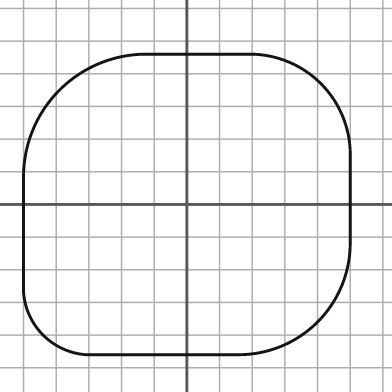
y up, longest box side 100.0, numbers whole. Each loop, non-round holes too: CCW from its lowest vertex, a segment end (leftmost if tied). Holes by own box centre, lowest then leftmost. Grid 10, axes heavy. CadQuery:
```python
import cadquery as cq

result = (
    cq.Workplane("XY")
    .moveTo(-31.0, -46.0)
    .lineTo(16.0, -46.0)
    .threePointArc((40.0, -36.0), (50.0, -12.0))
    .lineTo(50.0, 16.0)
    .threePointArc((41.0, 37.0), (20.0, 46.0))
    .lineTo(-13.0, 46.0)
    .threePointArc((-39.0, 35.0), (-50.0, 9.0))
    .lineTo(-50.0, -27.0)
    .threePointArc((-44.0, -40.0), (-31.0, -46.0))
    .close()
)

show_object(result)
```